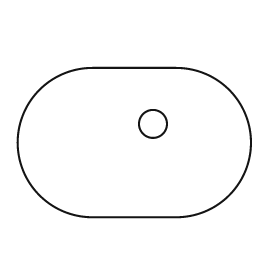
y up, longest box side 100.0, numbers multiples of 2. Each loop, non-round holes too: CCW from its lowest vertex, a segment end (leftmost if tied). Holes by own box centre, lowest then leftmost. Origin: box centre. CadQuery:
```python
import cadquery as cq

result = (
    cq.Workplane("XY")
    .moveTo(-18.0, -32.0)
    .lineTo(18.0, -32.0)
    .threePointArc((50.0, 0.0), (18.0, 32.0))
    .lineTo(-18.0, 32.0)
    .threePointArc((-50.0, 0.0), (-18.0, -32.0))
    .close()
    .moveTo(8.0, 8.0)
    .circle(6.0)
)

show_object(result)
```